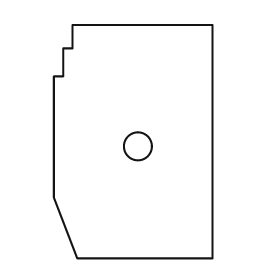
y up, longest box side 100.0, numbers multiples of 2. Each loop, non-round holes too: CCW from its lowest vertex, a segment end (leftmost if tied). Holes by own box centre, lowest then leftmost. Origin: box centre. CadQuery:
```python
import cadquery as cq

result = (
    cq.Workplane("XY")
    .moveTo(-24.0, -50.0)
    .lineTo(34.0, -50.0)
    .lineTo(34.0, 50.0)
    .lineTo(-26.0, 50.0)
    .lineTo(-26.0, 40.0)
    .lineTo(-30.0, 40.0)
    .lineTo(-30.0, 28.0)
    .lineTo(-34.0, 28.0)
    .lineTo(-34.0, -24.0)
    .close()
    .moveTo(2.0, -2.0)
    .circle(6.0)
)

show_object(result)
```